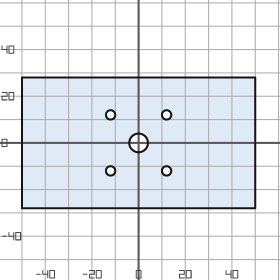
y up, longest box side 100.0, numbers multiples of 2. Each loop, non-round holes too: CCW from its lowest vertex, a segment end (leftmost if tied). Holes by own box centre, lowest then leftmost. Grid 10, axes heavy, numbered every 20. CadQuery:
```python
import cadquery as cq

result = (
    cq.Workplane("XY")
    .moveTo(-50.0, -28.0)
    .lineTo(50.0, -28.0)
    .lineTo(50.0, 28.0)
    .lineTo(-50.0, 28.0)
    .close()
    .moveTo(-12.0, -12.0)
    .circle(2.0)
    .moveTo(12.0, -12.0)
    .circle(2.0)
    .moveTo(0.0, 0.0)
    .circle(4.0)
    .moveTo(-12.0, 12.0)
    .circle(2.0)
    .moveTo(12.0, 12.0)
    .circle(2.0)
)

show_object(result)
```